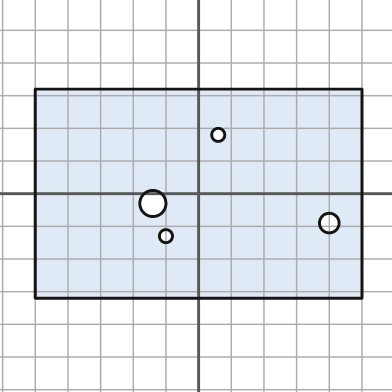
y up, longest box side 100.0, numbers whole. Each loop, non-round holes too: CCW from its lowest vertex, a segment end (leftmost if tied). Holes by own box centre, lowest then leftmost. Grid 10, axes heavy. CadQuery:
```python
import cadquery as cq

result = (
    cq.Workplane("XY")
    .moveTo(-50.0, -32.0)
    .lineTo(50.0, -32.0)
    .lineTo(50.0, 32.0)
    .lineTo(-50.0, 32.0)
    .close()
    .moveTo(-10.0, -13.0)
    .circle(2.0)
    .moveTo(40.0, -9.0)
    .circle(3.0)
    .moveTo(-14.0, -3.0)
    .circle(4.0)
    .moveTo(6.0, 18.0)
    .circle(2.0)
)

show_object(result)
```